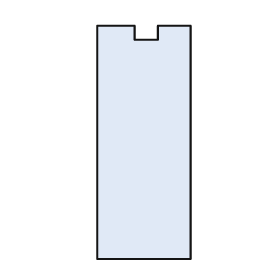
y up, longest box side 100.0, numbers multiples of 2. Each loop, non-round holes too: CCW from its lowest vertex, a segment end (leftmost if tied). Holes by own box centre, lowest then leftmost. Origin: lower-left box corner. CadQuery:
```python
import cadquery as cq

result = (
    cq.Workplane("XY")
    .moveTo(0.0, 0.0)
    .lineTo(40.0, 0.0)
    .lineTo(40.0, 100.0)
    .lineTo(26.0, 100.0)
    .lineTo(26.0, 94.0)
    .lineTo(16.0, 94.0)
    .lineTo(16.0, 100.0)
    .lineTo(0.0, 100.0)
    .close()
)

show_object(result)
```